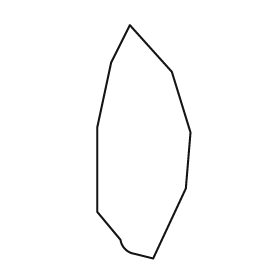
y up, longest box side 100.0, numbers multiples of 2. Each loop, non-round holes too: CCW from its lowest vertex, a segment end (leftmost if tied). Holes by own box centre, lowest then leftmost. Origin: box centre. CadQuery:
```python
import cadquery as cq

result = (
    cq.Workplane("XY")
    .moveTo(4.0, -50.0)
    .lineTo(18.0, -20.0)
    .lineTo(20.0, 4.0)
    .lineTo(12.0, 30.0)
    .lineTo(-6.0, 50.0)
    .lineTo(-14.0, 34.0)
    .lineTo(-20.0, 6.0)
    .lineTo(-20.0, -30.0)
    .lineTo(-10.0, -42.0)
    .threePointArc((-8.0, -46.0), (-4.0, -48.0))
    .close()
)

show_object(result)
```